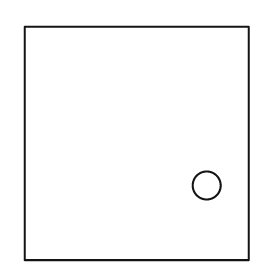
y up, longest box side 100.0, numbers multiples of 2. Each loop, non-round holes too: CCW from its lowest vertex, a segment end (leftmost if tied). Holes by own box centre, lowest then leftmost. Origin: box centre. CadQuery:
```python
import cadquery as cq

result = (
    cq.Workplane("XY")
    .moveTo(-48.0, -50.0)
    .lineTo(48.0, -50.0)
    .lineTo(48.0, 50.0)
    .lineTo(-48.0, 50.0)
    .close()
    .moveTo(30.0, -18.0)
    .circle(6.0)
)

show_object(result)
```